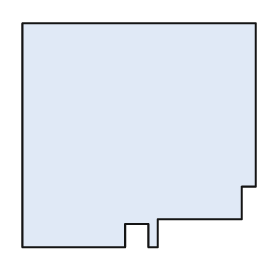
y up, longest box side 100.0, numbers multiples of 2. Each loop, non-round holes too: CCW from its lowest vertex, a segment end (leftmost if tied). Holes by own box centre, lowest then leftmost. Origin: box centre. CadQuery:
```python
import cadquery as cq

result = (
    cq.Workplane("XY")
    .moveTo(-50.0, -48.0)
    .lineTo(-6.0, -48.0)
    .lineTo(-6.0, -38.0)
    .lineTo(4.0, -38.0)
    .lineTo(4.0, -48.0)
    .lineTo(8.0, -48.0)
    .lineTo(8.0, -36.0)
    .lineTo(44.0, -36.0)
    .lineTo(44.0, -22.0)
    .lineTo(50.0, -22.0)
    .lineTo(50.0, 48.0)
    .lineTo(-50.0, 48.0)
    .close()
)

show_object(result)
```